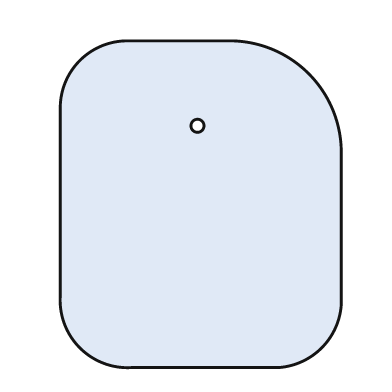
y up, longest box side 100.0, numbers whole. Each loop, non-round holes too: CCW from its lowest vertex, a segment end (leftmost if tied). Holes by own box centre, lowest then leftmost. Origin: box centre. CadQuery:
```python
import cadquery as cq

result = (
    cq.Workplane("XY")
    .moveTo(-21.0, -50.0)
    .lineTo(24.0, -50.0)
    .threePointArc((37.0, -44.0), (43.0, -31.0))
    .lineTo(43.0, 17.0)
    .threePointArc((33.0, 40.0), (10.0, 50.0))
    .lineTo(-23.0, 50.0)
    .threePointArc((-37.0, 44.0), (-43.0, 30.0))
    .lineTo(-43.0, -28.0)
    .threePointArc((-37.0, -44.0), (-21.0, -50.0))
    .close()
    .moveTo(-1.0, 24.0)
    .circle(2.0)
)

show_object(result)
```